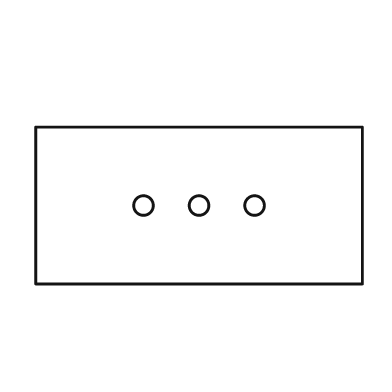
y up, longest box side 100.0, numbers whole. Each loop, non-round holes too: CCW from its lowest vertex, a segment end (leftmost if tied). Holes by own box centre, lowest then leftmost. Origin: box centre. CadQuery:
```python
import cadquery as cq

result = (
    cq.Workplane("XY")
    .moveTo(-50.0, -24.0)
    .lineTo(50.0, -24.0)
    .lineTo(50.0, 24.0)
    .lineTo(-50.0, 24.0)
    .close()
    .moveTo(-17.0, 0.0)
    .circle(3.0)
    .moveTo(0.0, 0.0)
    .circle(3.0)
    .moveTo(17.0, 0.0)
    .circle(3.0)
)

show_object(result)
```